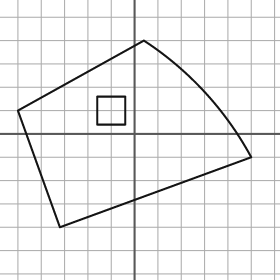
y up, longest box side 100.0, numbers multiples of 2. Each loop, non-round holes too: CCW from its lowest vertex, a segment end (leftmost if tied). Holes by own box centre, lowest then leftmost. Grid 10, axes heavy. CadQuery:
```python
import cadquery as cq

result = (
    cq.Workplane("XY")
    .moveTo(-32.0, -40.0)
    .lineTo(50.0, -10.0)
    .threePointArc((30.0, 18.0), (4.0, 40.0))
    .lineTo(-50.0, 10.0)
    .close()
    .moveTo(-16.0, 4.0)
    .lineTo(-4.0, 4.0)
    .lineTo(-4.0, 16.0)
    .lineTo(-16.0, 16.0)
    .close()
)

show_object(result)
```